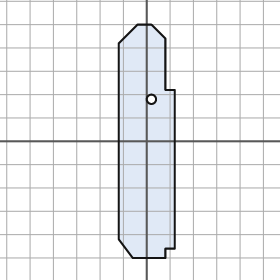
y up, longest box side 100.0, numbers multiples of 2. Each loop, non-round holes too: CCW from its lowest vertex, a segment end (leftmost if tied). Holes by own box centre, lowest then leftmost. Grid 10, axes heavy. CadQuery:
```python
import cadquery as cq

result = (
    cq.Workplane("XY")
    .moveTo(-6.0, -50.0)
    .lineTo(8.0, -50.0)
    .lineTo(8.0, -46.0)
    .lineTo(12.0, -46.0)
    .lineTo(12.0, 22.0)
    .lineTo(8.0, 22.0)
    .lineTo(8.0, 44.0)
    .lineTo(2.0, 50.0)
    .lineTo(-4.0, 50.0)
    .lineTo(-12.0, 42.0)
    .lineTo(-12.0, -42.0)
    .close()
    .moveTo(2.0, 18.0)
    .circle(2.0)
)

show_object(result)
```